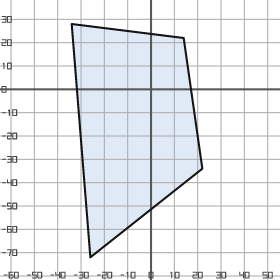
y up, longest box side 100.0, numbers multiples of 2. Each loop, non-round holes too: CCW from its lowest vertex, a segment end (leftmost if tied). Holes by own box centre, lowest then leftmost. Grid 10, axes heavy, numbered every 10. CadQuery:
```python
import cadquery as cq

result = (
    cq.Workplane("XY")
    .moveTo(-26.0, -72.0)
    .lineTo(22.0, -34.0)
    .lineTo(14.0, 22.0)
    .lineTo(-34.0, 28.0)
    .close()
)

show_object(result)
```